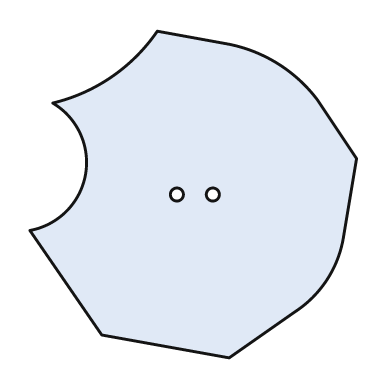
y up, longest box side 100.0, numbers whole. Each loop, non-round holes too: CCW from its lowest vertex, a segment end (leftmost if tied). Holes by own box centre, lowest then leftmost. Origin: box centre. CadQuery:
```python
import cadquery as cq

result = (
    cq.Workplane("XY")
    .moveTo(11.0, -50.0)
    .lineTo(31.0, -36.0)
    .threePointArc((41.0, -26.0), (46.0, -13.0))
    .lineTo(50.0, 11.0)
    .lineTo(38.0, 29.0)
    .threePointArc((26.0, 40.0), (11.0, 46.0))
    .lineTo(-11.0, 50.0)
    .threePointArc((-25.0, 36.0), (-43.0, 28.0))
    .threePointArc((-33.0, 6.0), (-50.0, -11.0))
    .lineTo(-28.0, -43.0)
    .close()
    .moveTo(-5.0, 0.0)
    .circle(2.0)
    .moveTo(6.0, 0.0)
    .circle(2.0)
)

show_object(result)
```